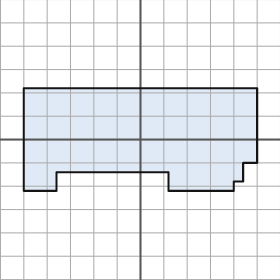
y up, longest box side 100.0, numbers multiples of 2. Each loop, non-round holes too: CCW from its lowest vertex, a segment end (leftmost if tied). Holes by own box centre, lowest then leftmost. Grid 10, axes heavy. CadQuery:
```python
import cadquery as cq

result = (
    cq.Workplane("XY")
    .moveTo(-50.0, -22.0)
    .lineTo(-36.0, -22.0)
    .lineTo(-36.0, -14.0)
    .lineTo(12.0, -14.0)
    .lineTo(12.0, -22.0)
    .lineTo(40.0, -22.0)
    .lineTo(40.0, -18.0)
    .lineTo(44.0, -18.0)
    .lineTo(44.0, -10.0)
    .lineTo(50.0, -10.0)
    .lineTo(50.0, 22.0)
    .lineTo(-50.0, 22.0)
    .close()
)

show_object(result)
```